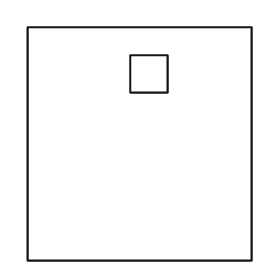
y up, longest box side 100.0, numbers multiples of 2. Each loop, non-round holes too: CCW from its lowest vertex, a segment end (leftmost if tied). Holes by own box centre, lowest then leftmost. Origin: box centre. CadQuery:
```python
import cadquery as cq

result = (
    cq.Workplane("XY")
    .moveTo(-48.0, -50.0)
    .lineTo(48.0, -50.0)
    .lineTo(48.0, 50.0)
    .lineTo(-48.0, 50.0)
    .close()
    .moveTo(-4.0, 22.0)
    .lineTo(12.0, 22.0)
    .lineTo(12.0, 38.0)
    .lineTo(-4.0, 38.0)
    .close()
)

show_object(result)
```